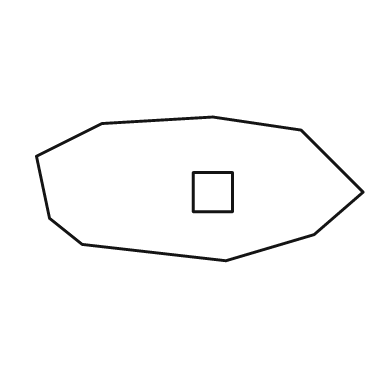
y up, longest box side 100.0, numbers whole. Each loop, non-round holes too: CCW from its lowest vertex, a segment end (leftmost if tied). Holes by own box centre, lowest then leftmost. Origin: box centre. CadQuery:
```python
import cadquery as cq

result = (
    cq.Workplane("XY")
    .moveTo(8.0, -22.0)
    .lineTo(35.0, -14.0)
    .lineTo(50.0, -1.0)
    .lineTo(31.0, 18.0)
    .lineTo(4.0, 22.0)
    .lineTo(-30.0, 20.0)
    .lineTo(-50.0, 10.0)
    .lineTo(-46.0, -9.0)
    .lineTo(-36.0, -17.0)
    .close()
    .moveTo(-2.0, -7.0)
    .lineTo(10.0, -7.0)
    .lineTo(10.0, 5.0)
    .lineTo(-2.0, 5.0)
    .close()
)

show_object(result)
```